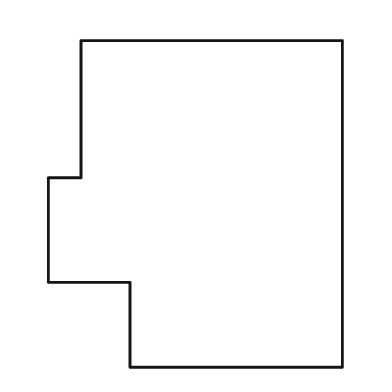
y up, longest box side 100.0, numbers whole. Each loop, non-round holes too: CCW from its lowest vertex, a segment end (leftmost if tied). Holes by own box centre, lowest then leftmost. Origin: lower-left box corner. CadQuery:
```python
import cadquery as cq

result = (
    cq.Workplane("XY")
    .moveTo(25.0, 0.0)
    .lineTo(90.0, 0.0)
    .lineTo(90.0, 100.0)
    .lineTo(10.0, 100.0)
    .lineTo(10.0, 58.0)
    .lineTo(0.0, 58.0)
    .lineTo(0.0, 26.0)
    .lineTo(25.0, 26.0)
    .close()
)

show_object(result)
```